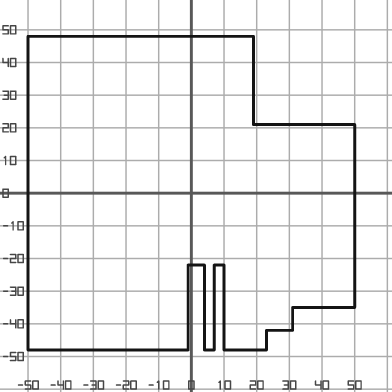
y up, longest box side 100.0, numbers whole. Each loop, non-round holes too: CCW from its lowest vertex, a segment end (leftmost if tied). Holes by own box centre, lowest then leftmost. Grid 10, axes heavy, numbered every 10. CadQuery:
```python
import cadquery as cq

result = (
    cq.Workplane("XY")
    .moveTo(-50.0, -48.0)
    .lineTo(-1.0, -48.0)
    .lineTo(-1.0, -22.0)
    .lineTo(4.0, -22.0)
    .lineTo(4.0, -48.0)
    .lineTo(7.0, -48.0)
    .lineTo(7.0, -22.0)
    .lineTo(10.0, -22.0)
    .lineTo(10.0, -48.0)
    .lineTo(23.0, -48.0)
    .lineTo(23.0, -42.0)
    .lineTo(31.0, -42.0)
    .lineTo(31.0, -35.0)
    .lineTo(50.0, -35.0)
    .lineTo(50.0, 21.0)
    .lineTo(19.0, 21.0)
    .lineTo(19.0, 48.0)
    .lineTo(-50.0, 48.0)
    .close()
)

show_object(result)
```